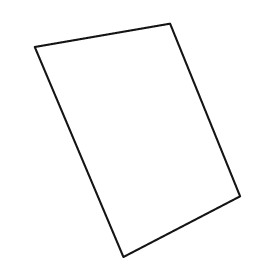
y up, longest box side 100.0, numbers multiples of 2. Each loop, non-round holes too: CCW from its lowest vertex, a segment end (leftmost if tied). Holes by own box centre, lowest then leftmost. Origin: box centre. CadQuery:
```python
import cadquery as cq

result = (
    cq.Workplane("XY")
    .moveTo(-6.0, -50.0)
    .lineTo(44.0, -24.0)
    .lineTo(14.0, 50.0)
    .lineTo(-44.0, 40.0)
    .close()
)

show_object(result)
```